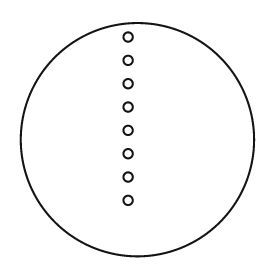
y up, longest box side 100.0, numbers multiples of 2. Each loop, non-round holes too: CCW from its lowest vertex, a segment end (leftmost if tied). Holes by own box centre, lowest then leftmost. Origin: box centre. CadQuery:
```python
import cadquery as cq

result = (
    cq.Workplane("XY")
    .moveTo(0.0, 0.0)
    .circle(50.0)
    .moveTo(-4.0, -26.0)
    .circle(2.0)
    .moveTo(-4.0, -16.0)
    .circle(2.0)
    .moveTo(-4.0, -6.0)
    .circle(2.0)
    .moveTo(-4.0, 4.0)
    .circle(2.0)
    .moveTo(-4.0, 14.0)
    .circle(2.0)
    .moveTo(-4.0, 24.0)
    .circle(2.0)
    .moveTo(-4.0, 34.0)
    .circle(2.0)
    .moveTo(-4.0, 44.0)
    .circle(2.0)
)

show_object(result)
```